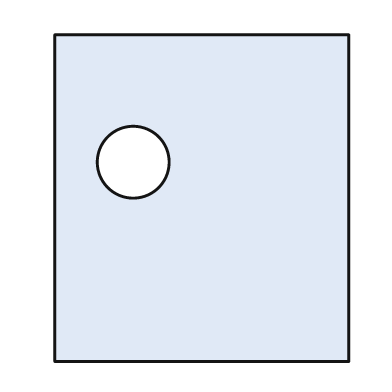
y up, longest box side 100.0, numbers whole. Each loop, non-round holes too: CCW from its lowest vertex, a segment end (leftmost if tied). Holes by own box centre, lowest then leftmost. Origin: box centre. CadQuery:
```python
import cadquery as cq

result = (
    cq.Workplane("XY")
    .moveTo(-45.0, -50.0)
    .lineTo(45.0, -50.0)
    .lineTo(45.0, 50.0)
    .lineTo(-45.0, 50.0)
    .close()
    .moveTo(-21.0, 11.0)
    .circle(11.0)
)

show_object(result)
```